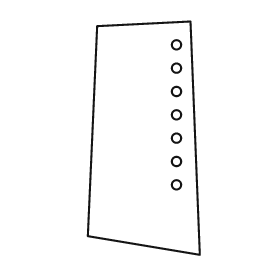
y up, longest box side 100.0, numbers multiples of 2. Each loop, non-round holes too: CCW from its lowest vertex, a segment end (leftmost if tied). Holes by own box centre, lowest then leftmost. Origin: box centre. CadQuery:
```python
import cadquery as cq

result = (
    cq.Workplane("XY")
    .moveTo(24.0, -50.0)
    .lineTo(20.0, 50.0)
    .lineTo(-20.0, 48.0)
    .lineTo(-24.0, -42.0)
    .close()
    .moveTo(14.0, -20.0)
    .circle(2.0)
    .moveTo(14.0, -10.0)
    .circle(2.0)
    .moveTo(14.0, 0.0)
    .circle(2.0)
    .moveTo(14.0, 10.0)
    .circle(2.0)
    .moveTo(14.0, 20.0)
    .circle(2.0)
    .moveTo(14.0, 30.0)
    .circle(2.0)
    .moveTo(14.0, 40.0)
    .circle(2.0)
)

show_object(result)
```